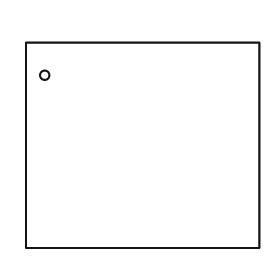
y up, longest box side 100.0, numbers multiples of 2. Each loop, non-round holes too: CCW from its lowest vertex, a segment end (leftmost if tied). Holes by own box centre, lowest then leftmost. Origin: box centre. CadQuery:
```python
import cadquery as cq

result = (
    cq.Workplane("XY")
    .moveTo(-50.0, -44.0)
    .lineTo(50.0, -44.0)
    .lineTo(50.0, 44.0)
    .lineTo(-50.0, 44.0)
    .close()
    .moveTo(-42.0, 30.0)
    .circle(2.0)
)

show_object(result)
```